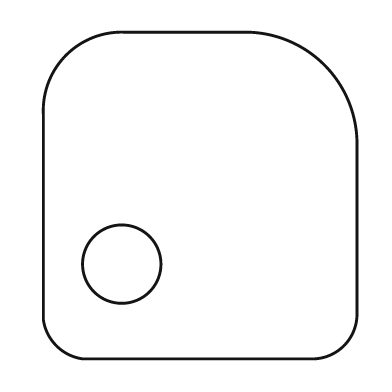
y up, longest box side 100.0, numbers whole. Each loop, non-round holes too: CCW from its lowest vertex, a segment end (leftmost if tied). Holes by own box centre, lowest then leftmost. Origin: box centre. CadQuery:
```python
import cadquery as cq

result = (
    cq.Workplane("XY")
    .moveTo(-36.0, -50.0)
    .lineTo(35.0, -50.0)
    .threePointArc((44.0, -46.0), (48.0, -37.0))
    .lineTo(48.0, 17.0)
    .threePointArc((38.0, 40.0), (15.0, 50.0))
    .lineTo(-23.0, 50.0)
    .threePointArc((-41.0, 43.0), (-48.0, 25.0))
    .lineTo(-48.0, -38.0)
    .threePointArc((-44.0, -46.0), (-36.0, -50.0))
    .close()
    .moveTo(-24.0, -21.0)
    .circle(12.0)
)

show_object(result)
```